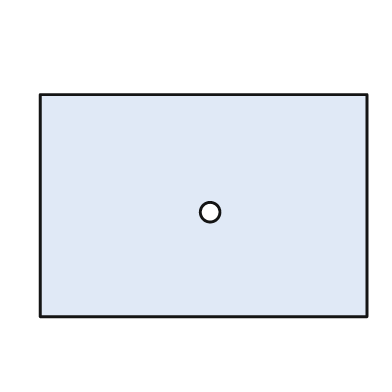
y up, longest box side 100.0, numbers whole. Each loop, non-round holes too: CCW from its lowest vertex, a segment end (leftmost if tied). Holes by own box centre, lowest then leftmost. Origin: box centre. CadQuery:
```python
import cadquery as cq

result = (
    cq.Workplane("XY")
    .moveTo(-50.0, -34.0)
    .lineTo(50.0, -34.0)
    .lineTo(50.0, 34.0)
    .lineTo(-50.0, 34.0)
    .close()
    .moveTo(2.0, -2.0)
    .circle(3.0)
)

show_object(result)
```